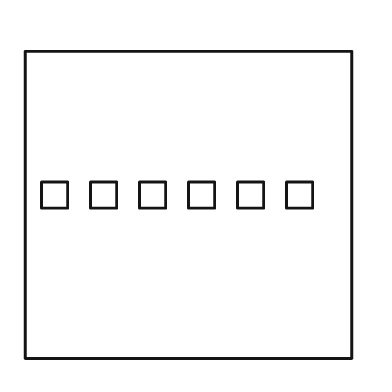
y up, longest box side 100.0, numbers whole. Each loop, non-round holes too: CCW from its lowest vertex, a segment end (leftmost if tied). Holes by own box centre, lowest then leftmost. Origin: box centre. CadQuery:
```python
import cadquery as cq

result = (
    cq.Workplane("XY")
    .moveTo(-50.0, -47.0)
    .lineTo(50.0, -47.0)
    .lineTo(50.0, 47.0)
    .lineTo(-50.0, 47.0)
    .close()
    .moveTo(-45.0, -1.0)
    .lineTo(-37.0, -1.0)
    .lineTo(-37.0, 7.0)
    .lineTo(-45.0, 7.0)
    .close()
    .moveTo(-30.0, -1.0)
    .lineTo(-22.0, -1.0)
    .lineTo(-22.0, 7.0)
    .lineTo(-30.0, 7.0)
    .close()
    .moveTo(-15.0, -1.0)
    .lineTo(-7.0, -1.0)
    .lineTo(-7.0, 7.0)
    .lineTo(-15.0, 7.0)
    .close()
    .moveTo(0.0, -1.0)
    .lineTo(8.0, -1.0)
    .lineTo(8.0, 7.0)
    .lineTo(0.0, 7.0)
    .close()
    .moveTo(15.0, -1.0)
    .lineTo(23.0, -1.0)
    .lineTo(23.0, 7.0)
    .lineTo(15.0, 7.0)
    .close()
    .moveTo(30.0, -1.0)
    .lineTo(38.0, -1.0)
    .lineTo(38.0, 7.0)
    .lineTo(30.0, 7.0)
    .close()
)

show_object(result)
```